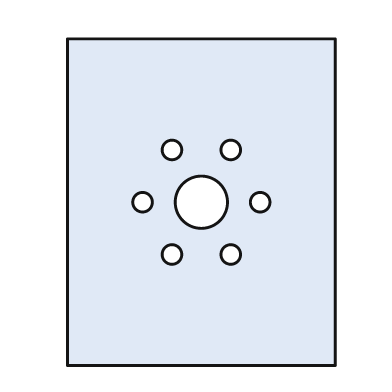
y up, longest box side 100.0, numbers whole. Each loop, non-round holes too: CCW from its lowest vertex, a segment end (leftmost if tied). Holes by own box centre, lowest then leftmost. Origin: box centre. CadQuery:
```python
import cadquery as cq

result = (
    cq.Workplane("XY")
    .moveTo(-41.0, -50.0)
    .lineTo(41.0, -50.0)
    .lineTo(41.0, 50.0)
    .lineTo(-41.0, 50.0)
    .close()
    .moveTo(-9.0, -16.0)
    .circle(3.0)
    .moveTo(9.0, -16.0)
    .circle(3.0)
    .moveTo(-18.0, 0.0)
    .circle(3.0)
    .moveTo(0.0, 0.0)
    .circle(8.0)
    .moveTo(18.0, 0.0)
    .circle(3.0)
    .moveTo(-9.0, 16.0)
    .circle(3.0)
    .moveTo(9.0, 16.0)
    .circle(3.0)
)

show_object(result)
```